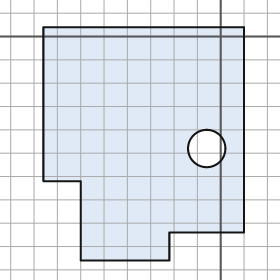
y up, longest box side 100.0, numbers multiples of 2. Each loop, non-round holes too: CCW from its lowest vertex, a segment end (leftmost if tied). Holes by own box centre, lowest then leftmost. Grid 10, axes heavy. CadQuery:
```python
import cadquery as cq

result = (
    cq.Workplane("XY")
    .moveTo(-60.0, -96.0)
    .lineTo(-22.0, -96.0)
    .lineTo(-22.0, -84.0)
    .lineTo(10.0, -84.0)
    .lineTo(10.0, 4.0)
    .lineTo(-76.0, 4.0)
    .lineTo(-76.0, -62.0)
    .lineTo(-60.0, -62.0)
    .close()
    .moveTo(-6.0, -48.0)
    .circle(8.0)
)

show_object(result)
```